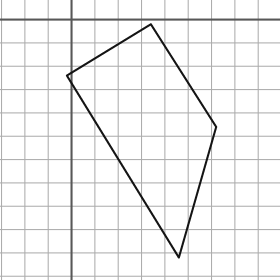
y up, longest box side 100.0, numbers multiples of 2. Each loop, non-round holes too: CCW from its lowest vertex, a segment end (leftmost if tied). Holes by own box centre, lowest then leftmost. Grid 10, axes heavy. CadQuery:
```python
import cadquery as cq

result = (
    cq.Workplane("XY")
    .moveTo(46.0, -102.0)
    .lineTo(62.0, -46.0)
    .lineTo(34.0, -2.0)
    .lineTo(-2.0, -24.0)
    .close()
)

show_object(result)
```